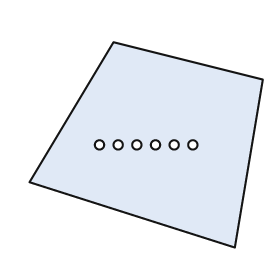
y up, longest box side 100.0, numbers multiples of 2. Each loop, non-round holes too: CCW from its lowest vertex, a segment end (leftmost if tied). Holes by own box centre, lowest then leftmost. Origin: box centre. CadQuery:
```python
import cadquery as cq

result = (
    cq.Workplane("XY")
    .moveTo(38.0, -44.0)
    .lineTo(50.0, 28.0)
    .lineTo(-14.0, 44.0)
    .lineTo(-50.0, -16.0)
    .close()
    .moveTo(-20.0, 0.0)
    .circle(2.0)
    .moveTo(-12.0, 0.0)
    .circle(2.0)
    .moveTo(-4.0, 0.0)
    .circle(2.0)
    .moveTo(4.0, 0.0)
    .circle(2.0)
    .moveTo(12.0, 0.0)
    .circle(2.0)
    .moveTo(20.0, 0.0)
    .circle(2.0)
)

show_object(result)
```